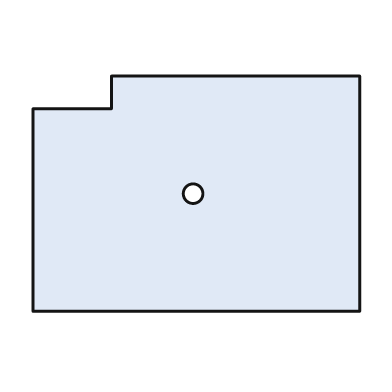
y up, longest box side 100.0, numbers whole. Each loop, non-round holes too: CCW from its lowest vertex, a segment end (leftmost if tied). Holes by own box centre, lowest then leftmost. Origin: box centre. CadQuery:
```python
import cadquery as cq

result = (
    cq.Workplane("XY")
    .moveTo(-50.0, -36.0)
    .lineTo(50.0, -36.0)
    .lineTo(50.0, 36.0)
    .lineTo(-26.0, 36.0)
    .lineTo(-26.0, 26.0)
    .lineTo(-50.0, 26.0)
    .close()
    .moveTo(-1.0, 0.0)
    .circle(3.0)
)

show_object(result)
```